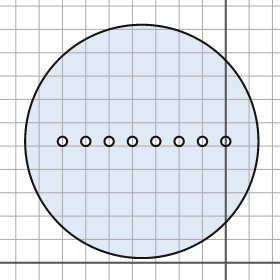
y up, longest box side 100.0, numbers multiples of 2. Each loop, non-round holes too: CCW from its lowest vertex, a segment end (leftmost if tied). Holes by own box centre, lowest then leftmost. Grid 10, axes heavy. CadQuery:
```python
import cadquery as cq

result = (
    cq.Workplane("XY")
    .moveTo(-36.0, 52.0)
    .circle(50.0)
    .moveTo(-70.0, 52.0)
    .circle(2.0)
    .moveTo(-60.0, 52.0)
    .circle(2.0)
    .moveTo(-50.0, 52.0)
    .circle(2.0)
    .moveTo(-40.0, 52.0)
    .circle(2.0)
    .moveTo(-30.0, 52.0)
    .circle(2.0)
    .moveTo(-20.0, 52.0)
    .circle(2.0)
    .moveTo(-10.0, 52.0)
    .circle(2.0)
    .moveTo(0.0, 52.0)
    .circle(2.0)
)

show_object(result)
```